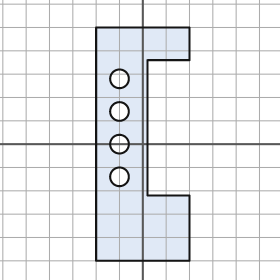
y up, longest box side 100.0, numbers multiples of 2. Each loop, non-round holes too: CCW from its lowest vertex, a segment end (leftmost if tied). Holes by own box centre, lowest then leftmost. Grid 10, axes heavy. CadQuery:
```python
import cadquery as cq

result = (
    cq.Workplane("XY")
    .moveTo(-20.0, -50.0)
    .lineTo(20.0, -50.0)
    .lineTo(20.0, -22.0)
    .lineTo(2.0, -22.0)
    .lineTo(2.0, 36.0)
    .lineTo(20.0, 36.0)
    .lineTo(20.0, 50.0)
    .lineTo(-20.0, 50.0)
    .close()
    .moveTo(-10.0, -14.0)
    .circle(4.0)
    .moveTo(-10.0, 0.0)
    .circle(4.0)
    .moveTo(-10.0, 14.0)
    .circle(4.0)
    .moveTo(-10.0, 28.0)
    .circle(4.0)
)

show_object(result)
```